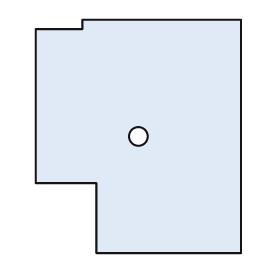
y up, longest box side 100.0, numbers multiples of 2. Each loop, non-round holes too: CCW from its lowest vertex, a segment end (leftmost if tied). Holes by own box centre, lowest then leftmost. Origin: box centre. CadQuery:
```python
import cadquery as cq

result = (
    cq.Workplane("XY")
    .moveTo(-18.0, -50.0)
    .lineTo(44.0, -50.0)
    .lineTo(44.0, 50.0)
    .lineTo(-24.0, 50.0)
    .lineTo(-24.0, 46.0)
    .lineTo(-44.0, 46.0)
    .lineTo(-44.0, -20.0)
    .lineTo(-18.0, -20.0)
    .close()
    .moveTo(0.0, 0.0)
    .circle(4.0)
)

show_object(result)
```